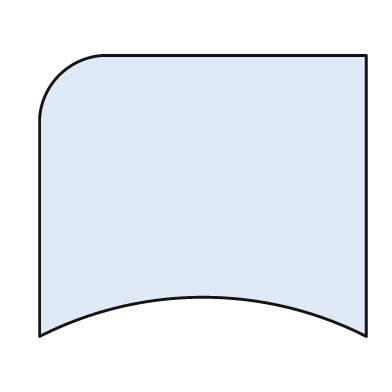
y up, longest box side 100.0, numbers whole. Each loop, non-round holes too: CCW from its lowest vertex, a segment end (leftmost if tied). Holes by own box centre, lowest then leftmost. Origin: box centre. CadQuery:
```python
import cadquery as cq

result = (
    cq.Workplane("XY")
    .moveTo(-50.0, -43.0)
    .threePointArc((0.0, -31.0), (50.0, -43.0))
    .lineTo(50.0, 43.0)
    .lineTo(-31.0, 43.0)
    .threePointArc((-44.0, 37.0), (-50.0, 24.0))
    .close()
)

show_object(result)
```